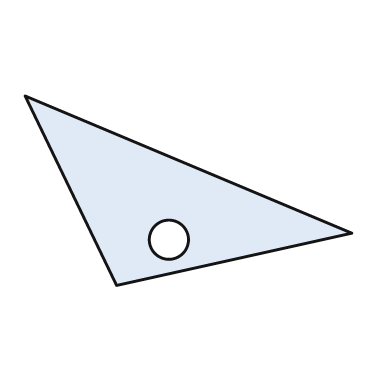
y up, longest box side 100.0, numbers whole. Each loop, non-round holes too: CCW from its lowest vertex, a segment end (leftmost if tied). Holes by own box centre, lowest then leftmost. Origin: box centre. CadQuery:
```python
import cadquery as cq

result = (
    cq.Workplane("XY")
    .moveTo(-22.0, -29.0)
    .lineTo(50.0, -13.0)
    .lineTo(-50.0, 29.0)
    .close()
    .moveTo(-6.0, -15.0)
    .circle(6.0)
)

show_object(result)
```